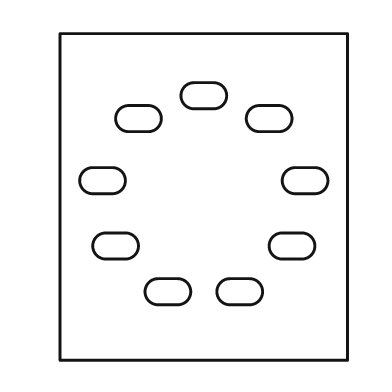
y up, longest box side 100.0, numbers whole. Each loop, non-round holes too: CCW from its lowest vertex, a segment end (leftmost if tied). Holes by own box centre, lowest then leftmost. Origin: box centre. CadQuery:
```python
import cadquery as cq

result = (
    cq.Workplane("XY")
    .moveTo(-44.0, -50.0)
    .lineTo(44.0, -50.0)
    .lineTo(44.0, 50.0)
    .lineTo(-44.0, 50.0)
    .close()
    .moveTo(-14.0, -33.0)
    .lineTo(-8.0, -33.0)
    .threePointArc((-4.0, -29.0), (-8.0, -25.0))
    .lineTo(-14.0, -25.0)
    .threePointArc((-18.0, -29.0), (-14.0, -33.0))
    .close()
    .moveTo(8.0, -33.0)
    .lineTo(14.0, -33.0)
    .threePointArc((18.0, -29.0), (14.0, -25.0))
    .lineTo(8.0, -25.0)
    .threePointArc((4.0, -29.0), (8.0, -33.0))
    .close()
    .moveTo(-30.0, -19.0)
    .lineTo(-24.0, -19.0)
    .threePointArc((-20.0, -15.0), (-24.0, -11.0))
    .lineTo(-30.0, -11.0)
    .threePointArc((-34.0, -15.0), (-30.0, -19.0))
    .close()
    .moveTo(24.0, -19.0)
    .lineTo(30.0, -19.0)
    .threePointArc((34.0, -15.0), (30.0, -11.0))
    .lineTo(24.0, -11.0)
    .threePointArc((20.0, -15.0), (24.0, -19.0))
    .close()
    .moveTo(-34.0, 1.0)
    .lineTo(-28.0, 1.0)
    .threePointArc((-24.0, 5.0), (-28.0, 9.0))
    .lineTo(-34.0, 9.0)
    .threePointArc((-38.0, 5.0), (-34.0, 1.0))
    .close()
    .moveTo(28.0, 1.0)
    .lineTo(34.0, 1.0)
    .threePointArc((38.0, 5.0), (34.0, 9.0))
    .lineTo(28.0, 9.0)
    .threePointArc((24.0, 5.0), (28.0, 1.0))
    .close()
    .moveTo(-23.0, 20.0)
    .lineTo(-17.0, 20.0)
    .threePointArc((-13.0, 24.0), (-17.0, 28.0))
    .lineTo(-23.0, 28.0)
    .threePointArc((-27.0, 24.0), (-23.0, 20.0))
    .close()
    .moveTo(17.0, 20.0)
    .lineTo(23.0, 20.0)
    .threePointArc((27.0, 24.0), (23.0, 28.0))
    .lineTo(17.0, 28.0)
    .threePointArc((13.0, 24.0), (17.0, 20.0))
    .close()
    .moveTo(-3.0, 27.0)
    .lineTo(3.0, 27.0)
    .threePointArc((7.0, 31.0), (3.0, 35.0))
    .lineTo(-3.0, 35.0)
    .threePointArc((-7.0, 31.0), (-3.0, 27.0))
    .close()
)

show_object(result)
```